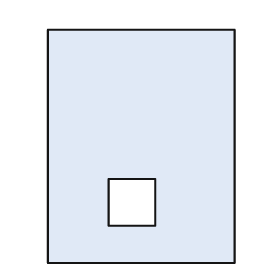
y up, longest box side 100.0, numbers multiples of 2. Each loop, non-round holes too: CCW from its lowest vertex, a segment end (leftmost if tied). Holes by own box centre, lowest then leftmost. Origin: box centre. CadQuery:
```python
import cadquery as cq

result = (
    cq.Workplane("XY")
    .moveTo(-40.0, -50.0)
    .lineTo(40.0, -50.0)
    .lineTo(40.0, 50.0)
    .lineTo(-40.0, 50.0)
    .close()
    .moveTo(-14.0, -34.0)
    .lineTo(6.0, -34.0)
    .lineTo(6.0, -14.0)
    .lineTo(-14.0, -14.0)
    .close()
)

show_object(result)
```